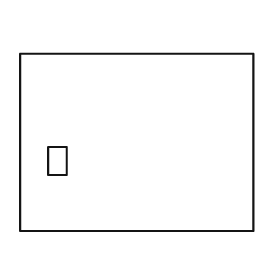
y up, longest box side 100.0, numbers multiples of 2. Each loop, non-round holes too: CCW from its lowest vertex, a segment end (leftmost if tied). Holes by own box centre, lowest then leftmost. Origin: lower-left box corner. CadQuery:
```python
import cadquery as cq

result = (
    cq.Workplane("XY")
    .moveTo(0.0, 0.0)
    .lineTo(100.0, 0.0)
    .lineTo(100.0, 76.0)
    .lineTo(0.0, 76.0)
    .close()
    .moveTo(12.0, 24.0)
    .lineTo(20.0, 24.0)
    .lineTo(20.0, 36.0)
    .lineTo(12.0, 36.0)
    .close()
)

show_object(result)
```